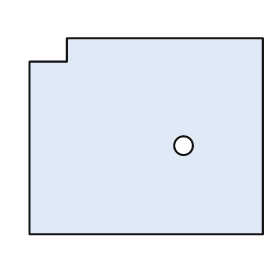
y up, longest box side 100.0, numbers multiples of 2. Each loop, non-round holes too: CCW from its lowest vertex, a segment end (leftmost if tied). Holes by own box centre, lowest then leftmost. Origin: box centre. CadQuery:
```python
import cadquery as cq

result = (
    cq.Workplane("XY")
    .moveTo(-50.0, -42.0)
    .lineTo(50.0, -42.0)
    .lineTo(50.0, 42.0)
    .lineTo(-34.0, 42.0)
    .lineTo(-34.0, 32.0)
    .lineTo(-50.0, 32.0)
    .close()
    .moveTo(16.0, -4.0)
    .circle(4.0)
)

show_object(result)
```